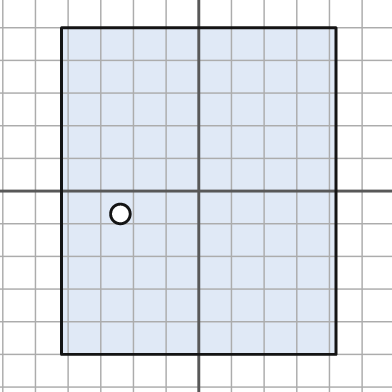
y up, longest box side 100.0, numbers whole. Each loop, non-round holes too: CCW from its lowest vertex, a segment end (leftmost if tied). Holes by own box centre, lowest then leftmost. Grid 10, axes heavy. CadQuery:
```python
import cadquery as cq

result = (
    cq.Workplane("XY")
    .moveTo(-42.0, -50.0)
    .lineTo(42.0, -50.0)
    .lineTo(42.0, 50.0)
    .lineTo(-42.0, 50.0)
    .close()
    .moveTo(-24.0, -7.0)
    .circle(3.0)
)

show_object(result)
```